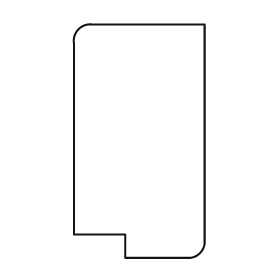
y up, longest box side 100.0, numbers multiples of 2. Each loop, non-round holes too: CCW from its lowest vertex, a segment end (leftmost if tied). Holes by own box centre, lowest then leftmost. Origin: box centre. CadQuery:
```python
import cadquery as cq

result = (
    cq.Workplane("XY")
    .moveTo(-6.0, -50.0)
    .lineTo(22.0, -50.0)
    .threePointArc((26.0, -48.0), (28.0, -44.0))
    .lineTo(28.0, 50.0)
    .lineTo(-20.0, 50.0)
    .threePointArc((-26.0, 48.0), (-28.0, 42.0))
    .lineTo(-28.0, -40.0)
    .lineTo(-6.0, -40.0)
    .close()
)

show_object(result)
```